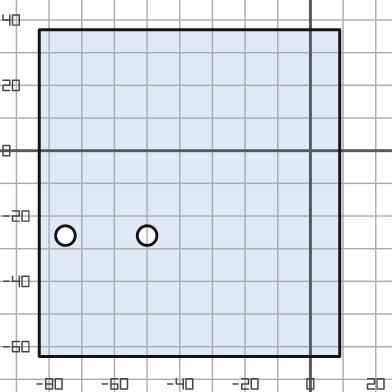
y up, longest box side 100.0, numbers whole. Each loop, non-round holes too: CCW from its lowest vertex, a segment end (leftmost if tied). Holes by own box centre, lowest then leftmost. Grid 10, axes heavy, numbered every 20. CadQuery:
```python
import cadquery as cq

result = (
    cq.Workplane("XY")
    .moveTo(-83.0, -63.0)
    .lineTo(9.0, -63.0)
    .lineTo(9.0, 37.0)
    .lineTo(-83.0, 37.0)
    .close()
    .moveTo(-75.0, -26.0)
    .circle(3.0)
    .moveTo(-50.0, -26.0)
    .circle(3.0)
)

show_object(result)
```